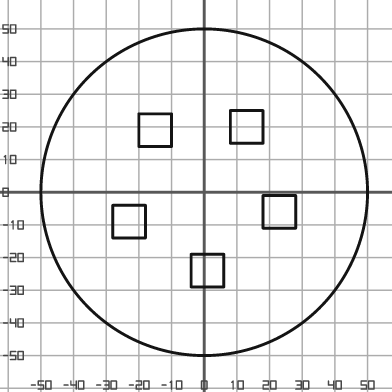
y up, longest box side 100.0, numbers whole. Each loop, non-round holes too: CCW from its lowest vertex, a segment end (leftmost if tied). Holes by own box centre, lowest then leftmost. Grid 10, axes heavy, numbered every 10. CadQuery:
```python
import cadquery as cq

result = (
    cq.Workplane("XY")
    .moveTo(0.0, 0.0)
    .circle(50.0)
    .moveTo(-4.0, -29.0)
    .lineTo(6.0, -29.0)
    .lineTo(6.0, -19.0)
    .lineTo(-4.0, -19.0)
    .close()
    .moveTo(-28.0, -14.0)
    .lineTo(-18.0, -14.0)
    .lineTo(-18.0, -4.0)
    .lineTo(-28.0, -4.0)
    .close()
    .moveTo(18.0, -11.0)
    .lineTo(28.0, -11.0)
    .lineTo(28.0, -1.0)
    .lineTo(18.0, -1.0)
    .close()
    .moveTo(-20.0, 14.0)
    .lineTo(-10.0, 14.0)
    .lineTo(-10.0, 24.0)
    .lineTo(-20.0, 24.0)
    .close()
    .moveTo(8.0, 15.0)
    .lineTo(18.0, 15.0)
    .lineTo(18.0, 25.0)
    .lineTo(8.0, 25.0)
    .close()
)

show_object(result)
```